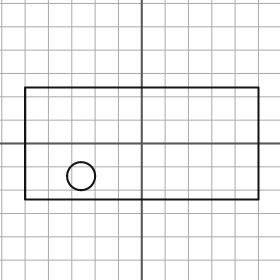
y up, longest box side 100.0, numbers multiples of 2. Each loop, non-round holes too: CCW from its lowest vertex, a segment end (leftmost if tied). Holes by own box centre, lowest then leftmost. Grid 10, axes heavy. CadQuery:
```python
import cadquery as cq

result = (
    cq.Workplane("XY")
    .moveTo(-50.0, -24.0)
    .lineTo(50.0, -24.0)
    .lineTo(50.0, 24.0)
    .lineTo(-50.0, 24.0)
    .close()
    .moveTo(-26.0, -14.0)
    .circle(6.0)
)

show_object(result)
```